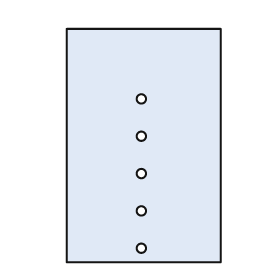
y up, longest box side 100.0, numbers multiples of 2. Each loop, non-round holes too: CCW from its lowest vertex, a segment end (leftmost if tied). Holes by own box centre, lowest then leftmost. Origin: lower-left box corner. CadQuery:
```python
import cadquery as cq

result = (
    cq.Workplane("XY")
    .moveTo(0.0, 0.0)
    .lineTo(66.0, 0.0)
    .lineTo(66.0, 100.0)
    .lineTo(0.0, 100.0)
    .close()
    .moveTo(32.0, 6.0)
    .circle(2.0)
    .moveTo(32.0, 22.0)
    .circle(2.0)
    .moveTo(32.0, 38.0)
    .circle(2.0)
    .moveTo(32.0, 54.0)
    .circle(2.0)
    .moveTo(32.0, 70.0)
    .circle(2.0)
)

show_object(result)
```